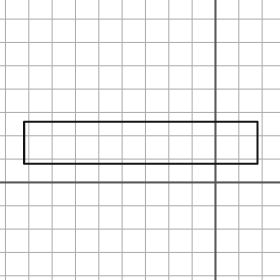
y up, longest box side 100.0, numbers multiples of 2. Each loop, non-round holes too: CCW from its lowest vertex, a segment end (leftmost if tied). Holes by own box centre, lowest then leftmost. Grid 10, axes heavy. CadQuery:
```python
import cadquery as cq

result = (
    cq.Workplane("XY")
    .moveTo(-82.0, 8.0)
    .lineTo(18.0, 8.0)
    .lineTo(18.0, 26.0)
    .lineTo(-82.0, 26.0)
    .close()
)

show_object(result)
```